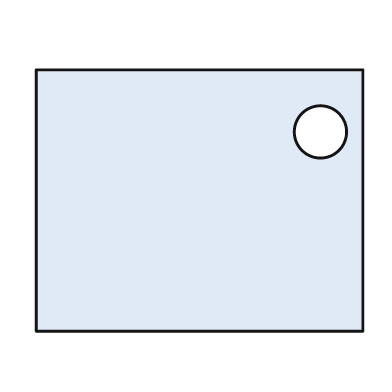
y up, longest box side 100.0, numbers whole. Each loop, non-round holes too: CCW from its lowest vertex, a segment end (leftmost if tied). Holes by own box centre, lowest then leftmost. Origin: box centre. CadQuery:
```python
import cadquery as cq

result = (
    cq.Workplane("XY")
    .moveTo(-50.0, -40.0)
    .lineTo(50.0, -40.0)
    .lineTo(50.0, 40.0)
    .lineTo(-50.0, 40.0)
    .close()
    .moveTo(37.0, 21.0)
    .circle(8.0)
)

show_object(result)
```